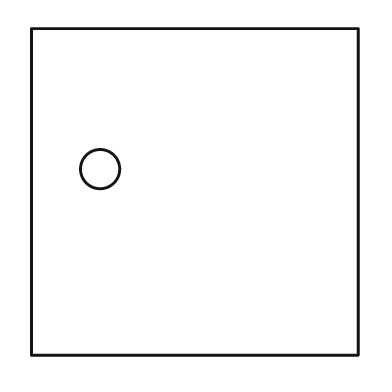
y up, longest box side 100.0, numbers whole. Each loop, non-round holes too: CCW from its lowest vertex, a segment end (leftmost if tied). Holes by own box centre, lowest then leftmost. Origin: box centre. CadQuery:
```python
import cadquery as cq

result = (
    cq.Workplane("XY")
    .moveTo(-50.0, -50.0)
    .lineTo(50.0, -50.0)
    .lineTo(50.0, 50.0)
    .lineTo(-50.0, 50.0)
    .close()
    .moveTo(-29.0, 7.0)
    .circle(6.0)
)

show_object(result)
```